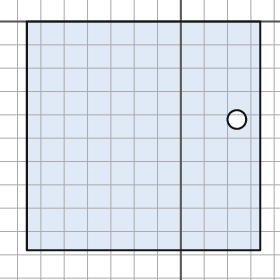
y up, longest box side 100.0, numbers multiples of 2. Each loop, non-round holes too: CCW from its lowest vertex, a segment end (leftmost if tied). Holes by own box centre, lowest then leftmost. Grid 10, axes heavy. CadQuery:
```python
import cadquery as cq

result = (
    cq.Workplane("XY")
    .moveTo(-66.0, -98.0)
    .lineTo(34.0, -98.0)
    .lineTo(34.0, 0.0)
    .lineTo(-66.0, 0.0)
    .close()
    .moveTo(24.0, -42.0)
    .circle(4.0)
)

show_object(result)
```